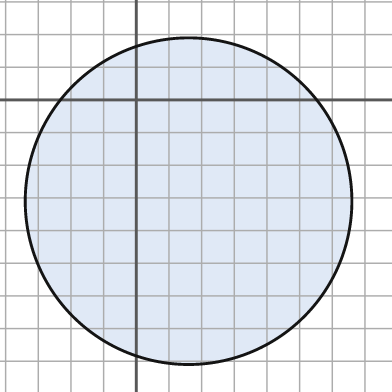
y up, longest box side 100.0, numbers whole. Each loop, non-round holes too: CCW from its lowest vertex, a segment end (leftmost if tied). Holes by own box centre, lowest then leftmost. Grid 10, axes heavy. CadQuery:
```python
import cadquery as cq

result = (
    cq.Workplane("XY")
    .moveTo(16.0, -31.0)
    .circle(50.0)
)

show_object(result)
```